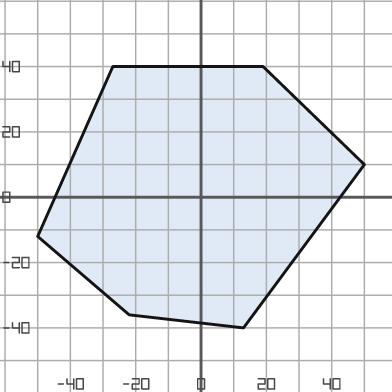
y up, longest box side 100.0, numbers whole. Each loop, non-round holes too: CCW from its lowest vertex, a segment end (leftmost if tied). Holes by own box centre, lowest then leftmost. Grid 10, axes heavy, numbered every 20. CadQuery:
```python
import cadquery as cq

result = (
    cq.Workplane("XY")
    .moveTo(13.0, -40.0)
    .lineTo(50.0, 10.0)
    .lineTo(19.0, 40.0)
    .lineTo(-27.0, 40.0)
    .lineTo(-50.0, -12.0)
    .lineTo(-22.0, -36.0)
    .close()
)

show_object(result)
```